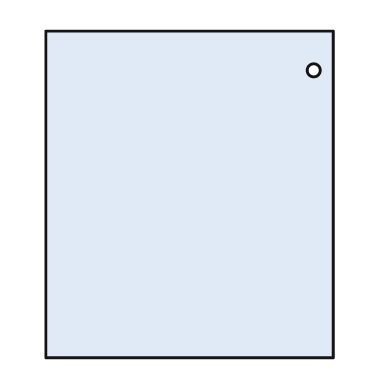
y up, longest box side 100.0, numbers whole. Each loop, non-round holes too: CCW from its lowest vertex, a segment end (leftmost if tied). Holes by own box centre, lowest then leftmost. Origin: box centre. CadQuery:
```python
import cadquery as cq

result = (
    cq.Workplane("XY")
    .moveTo(-44.0, -50.0)
    .lineTo(44.0, -50.0)
    .lineTo(44.0, 50.0)
    .lineTo(-44.0, 50.0)
    .close()
    .moveTo(38.0, 38.0)
    .circle(2.0)
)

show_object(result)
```